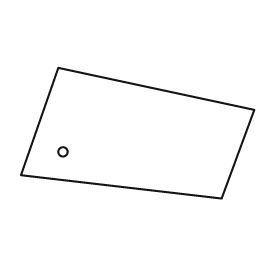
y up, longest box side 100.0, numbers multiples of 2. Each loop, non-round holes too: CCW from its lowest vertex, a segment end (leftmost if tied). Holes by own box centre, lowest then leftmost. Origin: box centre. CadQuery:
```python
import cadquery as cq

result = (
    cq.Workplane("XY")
    .moveTo(36.0, -28.0)
    .lineTo(50.0, 10.0)
    .lineTo(-34.0, 28.0)
    .lineTo(-50.0, -18.0)
    .close()
    .moveTo(-32.0, -8.0)
    .circle(2.0)
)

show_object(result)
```